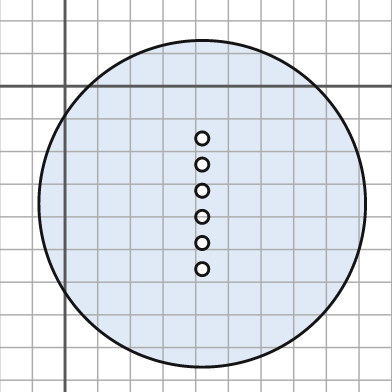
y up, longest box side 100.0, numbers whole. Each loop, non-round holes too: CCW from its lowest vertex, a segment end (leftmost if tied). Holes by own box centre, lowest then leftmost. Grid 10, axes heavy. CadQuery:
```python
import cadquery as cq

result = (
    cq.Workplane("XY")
    .moveTo(42.0, -36.0)
    .circle(50.0)
    .moveTo(42.0, -56.0)
    .circle(2.0)
    .moveTo(42.0, -48.0)
    .circle(2.0)
    .moveTo(42.0, -40.0)
    .circle(2.0)
    .moveTo(42.0, -32.0)
    .circle(2.0)
    .moveTo(42.0, -24.0)
    .circle(2.0)
    .moveTo(42.0, -16.0)
    .circle(2.0)
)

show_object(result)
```